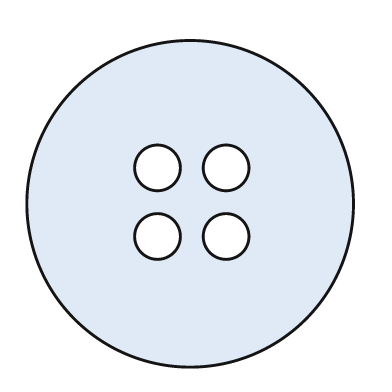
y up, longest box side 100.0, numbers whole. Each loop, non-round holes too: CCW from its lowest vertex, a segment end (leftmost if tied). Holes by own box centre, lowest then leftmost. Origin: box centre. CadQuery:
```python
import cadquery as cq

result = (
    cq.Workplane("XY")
    .moveTo(0.0, 0.0)
    .circle(50.0)
    .moveTo(-10.0, -10.0)
    .circle(7.0)
    .moveTo(11.0, -10.0)
    .circle(7.0)
    .moveTo(-10.0, 11.0)
    .circle(7.0)
    .moveTo(11.0, 11.0)
    .circle(7.0)
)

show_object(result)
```